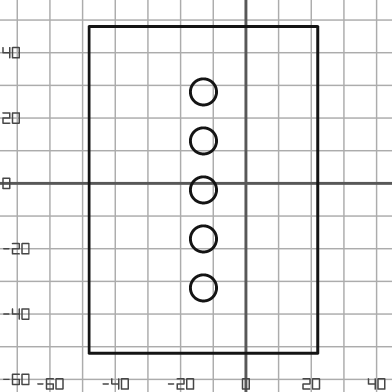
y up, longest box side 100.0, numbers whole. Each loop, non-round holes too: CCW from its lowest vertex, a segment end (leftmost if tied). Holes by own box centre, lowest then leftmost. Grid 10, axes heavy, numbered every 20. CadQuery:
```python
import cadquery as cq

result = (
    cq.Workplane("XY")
    .moveTo(-48.0, -52.0)
    .lineTo(22.0, -52.0)
    .lineTo(22.0, 48.0)
    .lineTo(-48.0, 48.0)
    .close()
    .moveTo(-13.0, -32.0)
    .circle(4.0)
    .moveTo(-13.0, -17.0)
    .circle(4.0)
    .moveTo(-13.0, -2.0)
    .circle(4.0)
    .moveTo(-13.0, 13.0)
    .circle(4.0)
    .moveTo(-13.0, 28.0)
    .circle(4.0)
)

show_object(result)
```